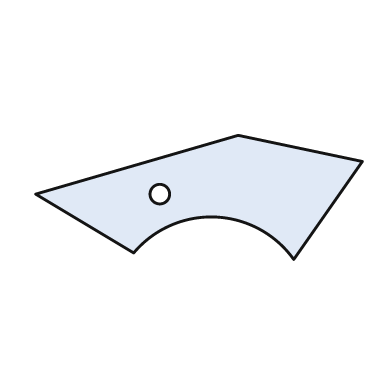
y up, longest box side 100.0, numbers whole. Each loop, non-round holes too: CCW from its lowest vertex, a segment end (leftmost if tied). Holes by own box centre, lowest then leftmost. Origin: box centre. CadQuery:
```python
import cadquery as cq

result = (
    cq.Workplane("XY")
    .moveTo(29.0, -19.0)
    .lineTo(50.0, 11.0)
    .lineTo(12.0, 19.0)
    .lineTo(-50.0, 1.0)
    .lineTo(-20.0, -17.0)
    .threePointArc((5.0, -6.0), (29.0, -19.0))
    .close()
    .moveTo(-12.0, 1.0)
    .circle(3.0)
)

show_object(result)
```